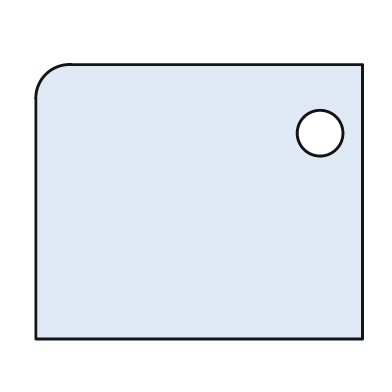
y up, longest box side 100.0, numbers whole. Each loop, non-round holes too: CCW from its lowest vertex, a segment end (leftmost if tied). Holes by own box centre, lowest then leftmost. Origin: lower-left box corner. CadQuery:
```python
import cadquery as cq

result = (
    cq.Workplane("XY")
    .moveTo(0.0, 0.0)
    .lineTo(100.0, 0.0)
    .lineTo(100.0, 84.0)
    .lineTo(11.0, 84.0)
    .threePointArc((3.0, 81.0), (0.0, 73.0))
    .close()
    .moveTo(87.0, 63.0)
    .circle(7.0)
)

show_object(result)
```